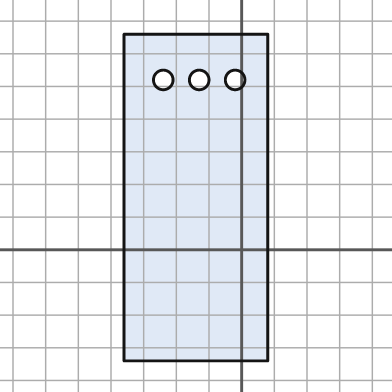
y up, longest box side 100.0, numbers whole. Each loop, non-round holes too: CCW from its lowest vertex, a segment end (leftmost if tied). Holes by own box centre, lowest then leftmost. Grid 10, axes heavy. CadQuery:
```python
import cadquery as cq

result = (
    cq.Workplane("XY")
    .moveTo(-36.0, -34.0)
    .lineTo(8.0, -34.0)
    .lineTo(8.0, 66.0)
    .lineTo(-36.0, 66.0)
    .close()
    .moveTo(-24.0, 52.0)
    .circle(3.0)
    .moveTo(-13.0, 52.0)
    .circle(3.0)
    .moveTo(-2.0, 52.0)
    .circle(3.0)
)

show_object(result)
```